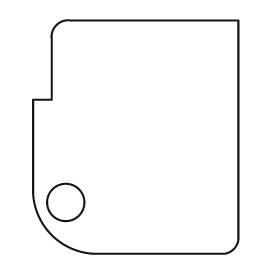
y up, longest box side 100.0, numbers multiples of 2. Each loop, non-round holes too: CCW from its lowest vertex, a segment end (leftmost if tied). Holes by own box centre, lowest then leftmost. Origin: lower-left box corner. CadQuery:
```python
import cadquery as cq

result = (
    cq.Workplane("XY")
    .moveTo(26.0, 0.0)
    .lineTo(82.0, 0.0)
    .threePointArc((86.0, 2.0), (88.0, 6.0))
    .lineTo(88.0, 100.0)
    .lineTo(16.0, 100.0)
    .threePointArc((10.0, 98.0), (8.0, 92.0))
    .lineTo(8.0, 66.0)
    .lineTo(0.0, 66.0)
    .lineTo(0.0, 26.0)
    .threePointArc((8.0, 8.0), (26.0, 0.0))
    .close()
    .moveTo(14.0, 22.0)
    .circle(8.0)
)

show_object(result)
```